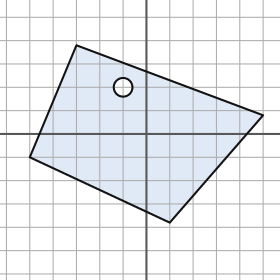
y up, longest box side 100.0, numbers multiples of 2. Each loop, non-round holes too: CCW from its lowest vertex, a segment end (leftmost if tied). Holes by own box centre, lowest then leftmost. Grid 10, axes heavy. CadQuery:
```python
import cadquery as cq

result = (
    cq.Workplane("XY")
    .moveTo(10.0, -38.0)
    .lineTo(50.0, 8.0)
    .lineTo(-30.0, 38.0)
    .lineTo(-50.0, -10.0)
    .close()
    .moveTo(-10.0, 20.0)
    .circle(4.0)
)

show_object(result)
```